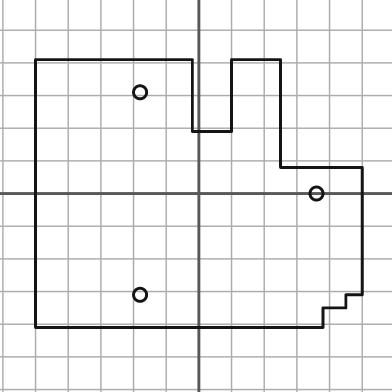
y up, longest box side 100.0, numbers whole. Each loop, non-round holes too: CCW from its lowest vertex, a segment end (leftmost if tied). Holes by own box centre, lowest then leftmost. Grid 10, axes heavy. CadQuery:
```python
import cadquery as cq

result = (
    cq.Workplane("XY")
    .moveTo(-50.0, -41.0)
    .lineTo(38.0, -41.0)
    .lineTo(38.0, -35.0)
    .lineTo(45.0, -35.0)
    .lineTo(45.0, -31.0)
    .lineTo(50.0, -31.0)
    .lineTo(50.0, 8.0)
    .lineTo(25.0, 8.0)
    .lineTo(25.0, 41.0)
    .lineTo(10.0, 41.0)
    .lineTo(10.0, 19.0)
    .lineTo(-2.0, 19.0)
    .lineTo(-2.0, 41.0)
    .lineTo(-50.0, 41.0)
    .close()
    .moveTo(-18.0, -31.0)
    .circle(2.0)
    .moveTo(36.0, 0.0)
    .circle(2.0)
    .moveTo(-18.0, 31.0)
    .circle(2.0)
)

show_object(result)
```